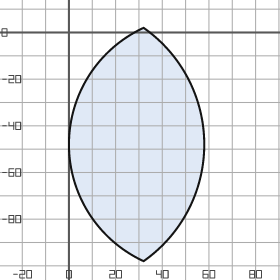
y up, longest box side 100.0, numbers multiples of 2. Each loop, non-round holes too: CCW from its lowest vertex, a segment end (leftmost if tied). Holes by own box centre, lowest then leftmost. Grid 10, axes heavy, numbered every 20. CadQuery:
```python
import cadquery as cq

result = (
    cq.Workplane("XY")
    .moveTo(32.0, -98.0)
    .threePointArc((58.0, -48.0), (32.0, 2.0))
    .threePointArc((0.0, -48.0), (32.0, -98.0))
    .close()
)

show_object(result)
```